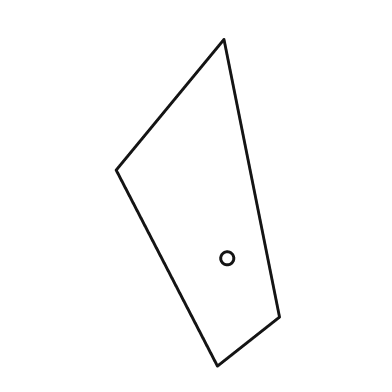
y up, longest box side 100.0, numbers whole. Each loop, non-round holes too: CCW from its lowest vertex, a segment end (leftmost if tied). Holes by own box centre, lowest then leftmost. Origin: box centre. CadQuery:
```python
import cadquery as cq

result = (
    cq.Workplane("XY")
    .moveTo(6.0, -50.0)
    .lineTo(25.0, -35.0)
    .lineTo(8.0, 50.0)
    .lineTo(-25.0, 10.0)
    .close()
    .moveTo(9.0, -17.0)
    .circle(2.0)
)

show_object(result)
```